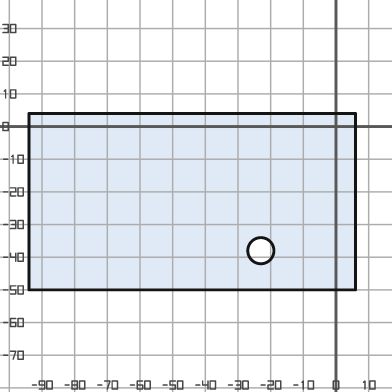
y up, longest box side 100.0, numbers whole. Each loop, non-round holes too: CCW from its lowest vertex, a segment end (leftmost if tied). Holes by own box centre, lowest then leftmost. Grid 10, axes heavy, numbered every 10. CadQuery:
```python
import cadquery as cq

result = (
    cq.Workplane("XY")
    .moveTo(-94.0, -50.0)
    .lineTo(6.0, -50.0)
    .lineTo(6.0, 4.0)
    .lineTo(-94.0, 4.0)
    .close()
    .moveTo(-23.0, -38.0)
    .circle(4.0)
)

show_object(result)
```